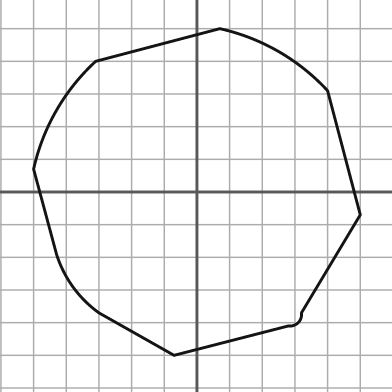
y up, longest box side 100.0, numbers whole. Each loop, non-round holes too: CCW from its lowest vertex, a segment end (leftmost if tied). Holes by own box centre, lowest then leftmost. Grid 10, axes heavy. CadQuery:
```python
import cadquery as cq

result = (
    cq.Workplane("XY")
    .moveTo(-7.0, -50.0)
    .lineTo(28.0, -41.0)
    .threePointArc((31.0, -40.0), (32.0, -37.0))
    .lineTo(50.0, -7.0)
    .lineTo(40.0, 31.0)
    .threePointArc((25.0, 43.0), (7.0, 50.0))
    .lineTo(-31.0, 40.0)
    .threePointArc((-43.0, 25.0), (-50.0, 7.0))
    .lineTo(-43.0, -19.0)
    .threePointArc((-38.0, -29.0), (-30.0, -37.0))
    .close()
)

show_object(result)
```